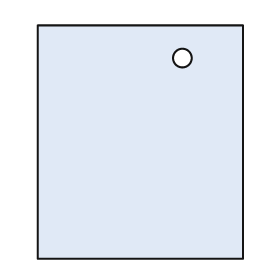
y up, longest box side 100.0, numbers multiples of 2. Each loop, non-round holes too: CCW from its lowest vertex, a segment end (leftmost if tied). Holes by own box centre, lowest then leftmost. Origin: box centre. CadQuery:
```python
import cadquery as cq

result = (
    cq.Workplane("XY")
    .moveTo(-44.0, -50.0)
    .lineTo(44.0, -50.0)
    .lineTo(44.0, 50.0)
    .lineTo(-44.0, 50.0)
    .close()
    .moveTo(18.0, 36.0)
    .circle(4.0)
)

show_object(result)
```